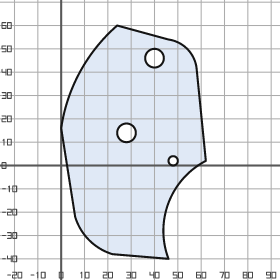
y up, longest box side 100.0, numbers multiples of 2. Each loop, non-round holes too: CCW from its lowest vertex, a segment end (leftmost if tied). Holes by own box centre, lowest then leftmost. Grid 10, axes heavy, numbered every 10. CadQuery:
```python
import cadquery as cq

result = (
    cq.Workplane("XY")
    .moveTo(46.0, -40.0)
    .threePointArc((46.0, -16.0), (62.0, 2.0))
    .lineTo(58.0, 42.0)
    .threePointArc((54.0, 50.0), (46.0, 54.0))
    .lineTo(24.0, 60.0)
    .threePointArc((8.0, 40.0), (0.0, 16.0))
    .lineTo(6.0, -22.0)
    .threePointArc((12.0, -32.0), (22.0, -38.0))
    .close()
    .moveTo(48.0, 2.0)
    .circle(2.0)
    .moveTo(28.0, 14.0)
    .circle(4.0)
    .moveTo(40.0, 46.0)
    .circle(4.0)
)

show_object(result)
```